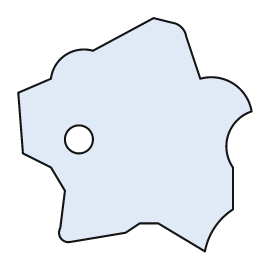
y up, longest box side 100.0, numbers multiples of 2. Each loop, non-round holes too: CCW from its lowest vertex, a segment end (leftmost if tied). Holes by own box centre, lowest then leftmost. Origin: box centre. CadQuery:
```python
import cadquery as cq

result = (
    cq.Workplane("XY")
    .moveTo(30.0, -50.0)
    .threePointArc((34.0, -40.0), (42.0, -32.0))
    .lineTo(42.0, -14.0)
    .threePointArc((40.0, 0.0), (50.0, 10.0))
    .threePointArc((42.0, 22.0), (28.0, 24.0))
    .lineTo(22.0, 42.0)
    .threePointArc((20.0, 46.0), (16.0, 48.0))
    .lineTo(8.0, 50.0)
    .lineTo(-18.0, 36.0)
    .threePointArc((-30.0, 34.0), (-36.0, 24.0))
    .lineTo(-50.0, 18.0)
    .lineTo(-48.0, -8.0)
    .lineTo(-36.0, -14.0)
    .lineTo(-30.0, -24.0)
    .lineTo(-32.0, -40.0)
    .threePointArc((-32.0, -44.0), (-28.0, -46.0))
    .lineTo(-4.0, -42.0)
    .lineTo(2.0, -38.0)
    .lineTo(10.0, -38.0)
    .close()
    .moveTo(-24.0, -2.0)
    .circle(6.0)
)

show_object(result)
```